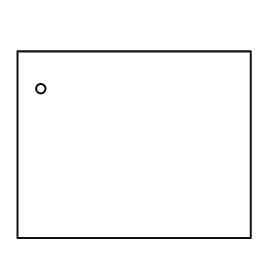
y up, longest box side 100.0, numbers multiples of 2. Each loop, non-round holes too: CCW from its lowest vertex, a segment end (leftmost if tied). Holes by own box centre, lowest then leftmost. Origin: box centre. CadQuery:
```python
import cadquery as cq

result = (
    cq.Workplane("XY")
    .moveTo(-50.0, -40.0)
    .lineTo(50.0, -40.0)
    .lineTo(50.0, 40.0)
    .lineTo(-50.0, 40.0)
    .close()
    .moveTo(-40.0, 24.0)
    .circle(2.0)
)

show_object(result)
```